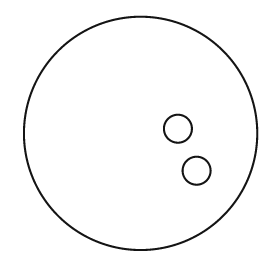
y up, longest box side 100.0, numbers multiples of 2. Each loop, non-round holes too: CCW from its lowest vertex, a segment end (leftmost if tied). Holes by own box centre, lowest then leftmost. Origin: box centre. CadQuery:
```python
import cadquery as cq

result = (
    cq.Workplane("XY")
    .moveTo(0.0, 0.0)
    .circle(50.0)
    .moveTo(24.0, -16.0)
    .circle(6.0)
    .moveTo(16.0, 2.0)
    .circle(6.0)
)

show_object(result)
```